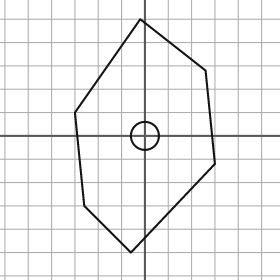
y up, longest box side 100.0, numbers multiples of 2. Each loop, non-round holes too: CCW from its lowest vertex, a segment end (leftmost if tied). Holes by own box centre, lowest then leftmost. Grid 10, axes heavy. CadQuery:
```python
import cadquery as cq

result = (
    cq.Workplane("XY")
    .moveTo(-6.0, -50.0)
    .lineTo(30.0, -12.0)
    .lineTo(26.0, 28.0)
    .lineTo(-2.0, 50.0)
    .lineTo(-30.0, 10.0)
    .lineTo(-26.0, -30.0)
    .close()
    .moveTo(0.0, 0.0)
    .circle(6.0)
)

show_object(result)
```